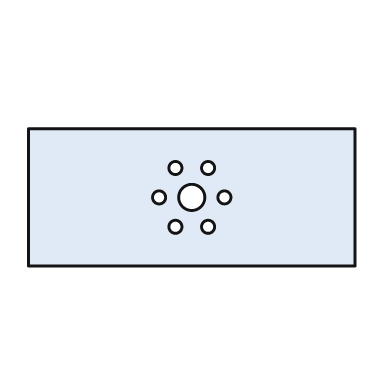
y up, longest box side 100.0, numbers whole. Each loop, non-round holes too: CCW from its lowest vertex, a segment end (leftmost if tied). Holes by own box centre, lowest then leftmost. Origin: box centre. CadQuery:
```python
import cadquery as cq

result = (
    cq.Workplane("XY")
    .moveTo(-50.0, -21.0)
    .lineTo(50.0, -21.0)
    .lineTo(50.0, 21.0)
    .lineTo(-50.0, 21.0)
    .close()
    .moveTo(-5.0, -9.0)
    .circle(2.0)
    .moveTo(5.0, -9.0)
    .circle(2.0)
    .moveTo(-10.0, 0.0)
    .circle(2.0)
    .moveTo(0.0, 0.0)
    .circle(4.0)
    .moveTo(10.0, 0.0)
    .circle(2.0)
    .moveTo(-5.0, 9.0)
    .circle(2.0)
    .moveTo(5.0, 9.0)
    .circle(2.0)
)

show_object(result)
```